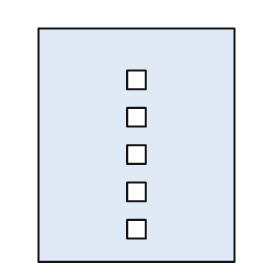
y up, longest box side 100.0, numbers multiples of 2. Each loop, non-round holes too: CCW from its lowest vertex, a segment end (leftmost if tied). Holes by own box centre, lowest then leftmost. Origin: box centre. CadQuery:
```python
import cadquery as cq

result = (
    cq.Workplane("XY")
    .moveTo(-42.0, -50.0)
    .lineTo(42.0, -50.0)
    .lineTo(42.0, 50.0)
    .lineTo(-42.0, 50.0)
    .close()
    .moveTo(-4.0, -40.0)
    .lineTo(4.0, -40.0)
    .lineTo(4.0, -32.0)
    .lineTo(-4.0, -32.0)
    .close()
    .moveTo(-4.0, -24.0)
    .lineTo(4.0, -24.0)
    .lineTo(4.0, -16.0)
    .lineTo(-4.0, -16.0)
    .close()
    .moveTo(-4.0, -8.0)
    .lineTo(4.0, -8.0)
    .lineTo(4.0, 0.0)
    .lineTo(-4.0, 0.0)
    .close()
    .moveTo(-4.0, 8.0)
    .lineTo(4.0, 8.0)
    .lineTo(4.0, 16.0)
    .lineTo(-4.0, 16.0)
    .close()
    .moveTo(-4.0, 24.0)
    .lineTo(4.0, 24.0)
    .lineTo(4.0, 32.0)
    .lineTo(-4.0, 32.0)
    .close()
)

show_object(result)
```